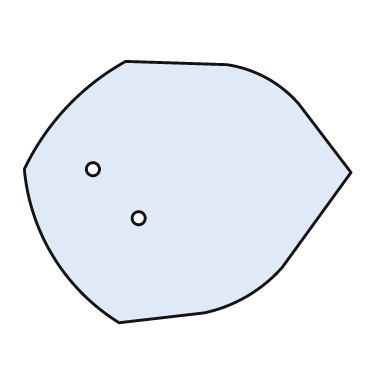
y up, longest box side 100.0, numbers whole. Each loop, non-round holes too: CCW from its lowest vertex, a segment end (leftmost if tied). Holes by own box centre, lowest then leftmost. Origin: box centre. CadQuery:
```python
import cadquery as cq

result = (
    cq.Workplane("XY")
    .moveTo(-21.0, -40.0)
    .lineTo(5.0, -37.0)
    .threePointArc((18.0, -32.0), (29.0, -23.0))
    .lineTo(50.0, 6.0)
    .lineTo(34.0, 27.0)
    .threePointArc((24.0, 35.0), (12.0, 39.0))
    .lineTo(-19.0, 40.0)
    .threePointArc((-37.0, 26.0), (-50.0, 7.0))
    .threePointArc((-41.0, -20.0), (-21.0, -40.0))
    .close()
    .moveTo(-15.0, -8.0)
    .circle(2.0)
    .moveTo(-29.0, 7.0)
    .circle(2.0)
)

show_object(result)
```